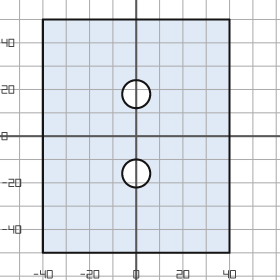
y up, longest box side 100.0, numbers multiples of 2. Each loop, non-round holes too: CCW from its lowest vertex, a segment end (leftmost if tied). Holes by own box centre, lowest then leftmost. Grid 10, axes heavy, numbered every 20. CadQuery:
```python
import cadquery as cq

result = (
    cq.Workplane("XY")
    .moveTo(-40.0, -50.0)
    .lineTo(40.0, -50.0)
    .lineTo(40.0, 50.0)
    .lineTo(-40.0, 50.0)
    .close()
    .moveTo(0.0, -16.0)
    .circle(6.0)
    .moveTo(0.0, 18.0)
    .circle(6.0)
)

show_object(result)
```